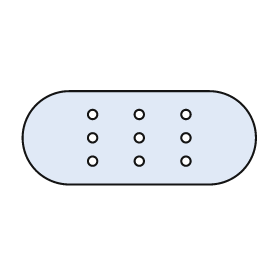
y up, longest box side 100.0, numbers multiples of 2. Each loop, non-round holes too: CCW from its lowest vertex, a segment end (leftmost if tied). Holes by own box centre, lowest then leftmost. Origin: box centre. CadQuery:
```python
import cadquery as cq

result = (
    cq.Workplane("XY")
    .moveTo(-30.0, -20.0)
    .lineTo(30.0, -20.0)
    .threePointArc((50.0, 0.0), (30.0, 20.0))
    .lineTo(-30.0, 20.0)
    .threePointArc((-50.0, 0.0), (-30.0, -20.0))
    .close()
    .moveTo(-20.0, -10.0)
    .circle(2.0)
    .moveTo(0.0, -10.0)
    .circle(2.0)
    .moveTo(20.0, -10.0)
    .circle(2.0)
    .moveTo(-20.0, 0.0)
    .circle(2.0)
    .moveTo(0.0, 0.0)
    .circle(2.0)
    .moveTo(20.0, 0.0)
    .circle(2.0)
    .moveTo(-20.0, 10.0)
    .circle(2.0)
    .moveTo(0.0, 10.0)
    .circle(2.0)
    .moveTo(20.0, 10.0)
    .circle(2.0)
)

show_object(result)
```